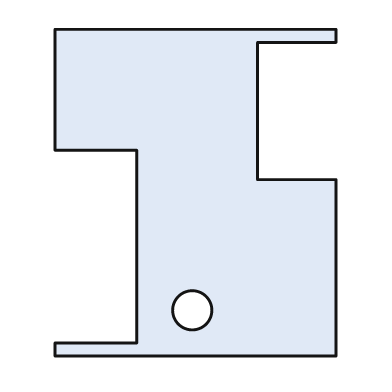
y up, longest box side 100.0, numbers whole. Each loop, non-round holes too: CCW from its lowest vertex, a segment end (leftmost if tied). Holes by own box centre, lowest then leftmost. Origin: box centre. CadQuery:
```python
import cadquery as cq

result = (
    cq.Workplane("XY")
    .moveTo(-43.0, -50.0)
    .lineTo(43.0, -50.0)
    .lineTo(43.0, 4.0)
    .lineTo(19.0, 4.0)
    .lineTo(19.0, 46.0)
    .lineTo(43.0, 46.0)
    .lineTo(43.0, 50.0)
    .lineTo(-43.0, 50.0)
    .lineTo(-43.0, 13.0)
    .lineTo(-18.0, 13.0)
    .lineTo(-18.0, -46.0)
    .lineTo(-43.0, -46.0)
    .close()
    .moveTo(-1.0, -36.0)
    .circle(6.0)
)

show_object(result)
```